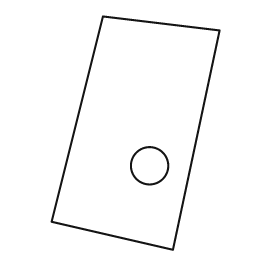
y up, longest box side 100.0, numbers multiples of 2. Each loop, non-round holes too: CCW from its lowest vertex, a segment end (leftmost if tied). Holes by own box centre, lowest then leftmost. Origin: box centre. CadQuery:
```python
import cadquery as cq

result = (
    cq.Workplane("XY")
    .moveTo(16.0, -50.0)
    .lineTo(36.0, 44.0)
    .lineTo(-14.0, 50.0)
    .lineTo(-36.0, -38.0)
    .close()
    .moveTo(6.0, -14.0)
    .circle(8.0)
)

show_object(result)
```